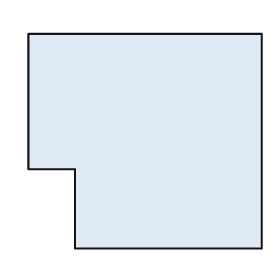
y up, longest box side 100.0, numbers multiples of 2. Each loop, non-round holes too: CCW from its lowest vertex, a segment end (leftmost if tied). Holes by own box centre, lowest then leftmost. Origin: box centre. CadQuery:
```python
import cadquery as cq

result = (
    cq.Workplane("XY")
    .moveTo(-30.0, -46.0)
    .lineTo(50.0, -46.0)
    .lineTo(50.0, 46.0)
    .lineTo(-50.0, 46.0)
    .lineTo(-50.0, -12.0)
    .lineTo(-30.0, -12.0)
    .close()
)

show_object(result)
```